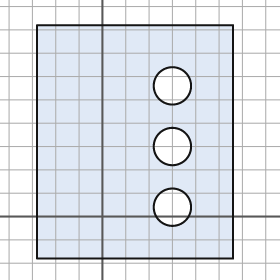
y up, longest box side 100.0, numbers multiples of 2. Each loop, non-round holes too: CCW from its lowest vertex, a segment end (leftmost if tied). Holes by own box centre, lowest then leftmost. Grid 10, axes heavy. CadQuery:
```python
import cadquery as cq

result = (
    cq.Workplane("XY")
    .moveTo(-28.0, -18.0)
    .lineTo(56.0, -18.0)
    .lineTo(56.0, 82.0)
    .lineTo(-28.0, 82.0)
    .close()
    .moveTo(30.0, 4.0)
    .circle(8.0)
    .moveTo(30.0, 30.0)
    .circle(8.0)
    .moveTo(30.0, 56.0)
    .circle(8.0)
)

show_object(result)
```